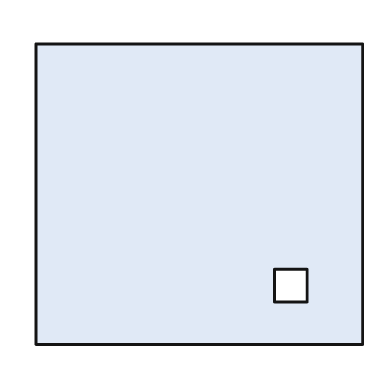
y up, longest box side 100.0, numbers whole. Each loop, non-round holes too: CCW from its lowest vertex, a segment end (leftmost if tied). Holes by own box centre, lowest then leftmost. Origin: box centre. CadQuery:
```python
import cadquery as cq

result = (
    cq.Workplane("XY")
    .moveTo(-50.0, -46.0)
    .lineTo(50.0, -46.0)
    .lineTo(50.0, 46.0)
    .lineTo(-50.0, 46.0)
    .close()
    .moveTo(23.0, -33.0)
    .lineTo(33.0, -33.0)
    .lineTo(33.0, -23.0)
    .lineTo(23.0, -23.0)
    .close()
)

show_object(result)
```